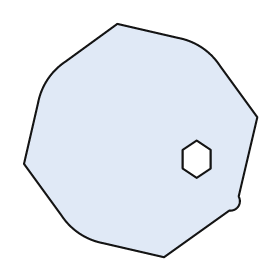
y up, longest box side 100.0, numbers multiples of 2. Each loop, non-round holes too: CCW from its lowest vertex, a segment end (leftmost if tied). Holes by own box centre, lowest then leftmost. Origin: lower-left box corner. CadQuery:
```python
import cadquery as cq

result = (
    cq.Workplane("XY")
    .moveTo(60.0, 0.0)
    .lineTo(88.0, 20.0)
    .threePointArc((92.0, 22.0), (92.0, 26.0))
    .lineTo(100.0, 60.0)
    .lineTo(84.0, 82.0)
    .threePointArc((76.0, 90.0), (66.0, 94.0))
    .lineTo(40.0, 100.0)
    .lineTo(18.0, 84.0)
    .threePointArc((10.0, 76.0), (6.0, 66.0))
    .lineTo(0.0, 40.0)
    .lineTo(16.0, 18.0)
    .threePointArc((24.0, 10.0), (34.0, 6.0))
    .close()
    .moveTo(74.0, 34.0)
    .lineTo(80.0, 38.0)
    .lineTo(80.0, 46.0)
    .lineTo(74.0, 50.0)
    .lineTo(68.0, 46.0)
    .lineTo(68.0, 38.0)
    .close()
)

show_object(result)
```